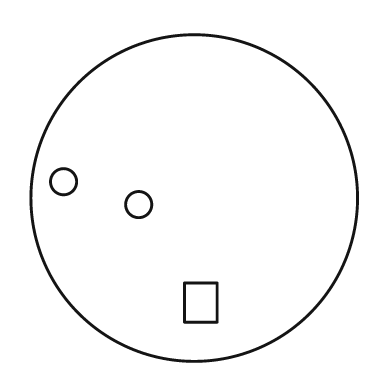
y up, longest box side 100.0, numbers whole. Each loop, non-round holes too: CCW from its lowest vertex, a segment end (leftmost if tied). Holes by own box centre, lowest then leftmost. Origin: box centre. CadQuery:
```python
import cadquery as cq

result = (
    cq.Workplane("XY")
    .moveTo(0.0, 0.0)
    .circle(50.0)
    .moveTo(-3.0, -38.0)
    .lineTo(7.0, -38.0)
    .lineTo(7.0, -26.0)
    .lineTo(-3.0, -26.0)
    .close()
    .moveTo(-17.0, -2.0)
    .circle(4.0)
    .moveTo(-40.0, 5.0)
    .circle(4.0)
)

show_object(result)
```